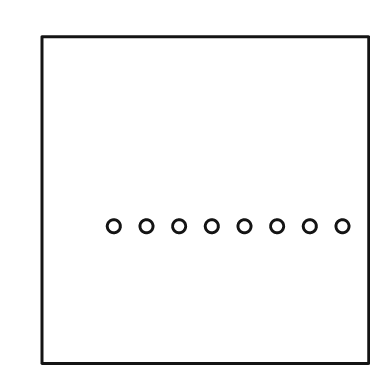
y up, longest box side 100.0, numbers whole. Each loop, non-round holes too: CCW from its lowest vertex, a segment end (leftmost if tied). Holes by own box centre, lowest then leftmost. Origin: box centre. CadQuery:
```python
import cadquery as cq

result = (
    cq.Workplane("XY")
    .moveTo(-50.0, -50.0)
    .lineTo(50.0, -50.0)
    .lineTo(50.0, 50.0)
    .lineTo(-50.0, 50.0)
    .close()
    .moveTo(-28.0, -8.0)
    .circle(2.0)
    .moveTo(-18.0, -8.0)
    .circle(2.0)
    .moveTo(-8.0, -8.0)
    .circle(2.0)
    .moveTo(2.0, -8.0)
    .circle(2.0)
    .moveTo(12.0, -8.0)
    .circle(2.0)
    .moveTo(22.0, -8.0)
    .circle(2.0)
    .moveTo(32.0, -8.0)
    .circle(2.0)
    .moveTo(42.0, -8.0)
    .circle(2.0)
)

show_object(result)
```